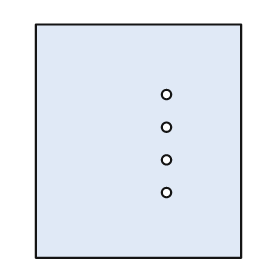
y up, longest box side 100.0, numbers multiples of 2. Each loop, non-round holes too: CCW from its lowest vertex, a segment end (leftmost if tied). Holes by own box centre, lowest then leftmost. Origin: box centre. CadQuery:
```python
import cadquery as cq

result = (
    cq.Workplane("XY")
    .moveTo(-44.0, -50.0)
    .lineTo(44.0, -50.0)
    .lineTo(44.0, 50.0)
    .lineTo(-44.0, 50.0)
    .close()
    .moveTo(12.0, -22.0)
    .circle(2.0)
    .moveTo(12.0, -8.0)
    .circle(2.0)
    .moveTo(12.0, 6.0)
    .circle(2.0)
    .moveTo(12.0, 20.0)
    .circle(2.0)
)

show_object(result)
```